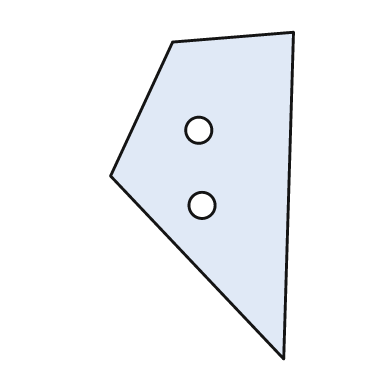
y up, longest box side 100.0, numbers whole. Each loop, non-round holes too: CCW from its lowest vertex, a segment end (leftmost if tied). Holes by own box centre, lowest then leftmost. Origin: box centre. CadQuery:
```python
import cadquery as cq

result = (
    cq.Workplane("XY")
    .moveTo(25.0, -50.0)
    .lineTo(28.0, 50.0)
    .lineTo(-9.0, 47.0)
    .lineTo(-28.0, 6.0)
    .close()
    .moveTo(0.0, -3.0)
    .circle(4.0)
    .moveTo(-1.0, 20.0)
    .circle(4.0)
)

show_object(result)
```